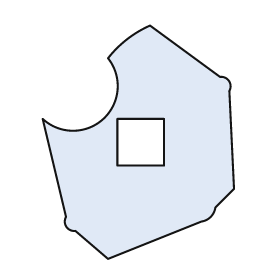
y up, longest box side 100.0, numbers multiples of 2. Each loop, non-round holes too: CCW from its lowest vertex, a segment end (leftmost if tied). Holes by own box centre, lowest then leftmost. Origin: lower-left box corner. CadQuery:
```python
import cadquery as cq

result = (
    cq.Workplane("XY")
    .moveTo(28.0, 0.0)
    .lineTo(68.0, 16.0)
    .threePointArc((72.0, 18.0), (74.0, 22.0))
    .lineTo(82.0, 30.0)
    .lineTo(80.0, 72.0)
    .threePointArc((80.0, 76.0), (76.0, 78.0))
    .lineTo(46.0, 100.0)
    .threePointArc((36.0, 94.0), (28.0, 86.0))
    .threePointArc((26.0, 60.0), (0.0, 60.0))
    .lineTo(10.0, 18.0)
    .threePointArc((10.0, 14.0), (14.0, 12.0))
    .close()
    .moveTo(32.0, 40.0)
    .lineTo(52.0, 40.0)
    .lineTo(52.0, 60.0)
    .lineTo(32.0, 60.0)
    .close()
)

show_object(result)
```